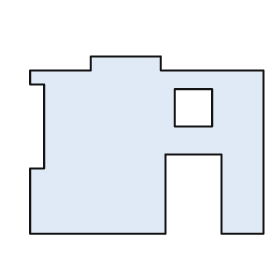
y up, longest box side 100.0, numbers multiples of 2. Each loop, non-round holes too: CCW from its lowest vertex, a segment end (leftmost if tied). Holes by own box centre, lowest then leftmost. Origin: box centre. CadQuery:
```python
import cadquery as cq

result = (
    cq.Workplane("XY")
    .moveTo(-50.0, -38.0)
    .lineTo(8.0, -38.0)
    .lineTo(8.0, -4.0)
    .lineTo(32.0, -4.0)
    .lineTo(32.0, -38.0)
    .lineTo(50.0, -38.0)
    .lineTo(50.0, 32.0)
    .lineTo(6.0, 32.0)
    .lineTo(6.0, 38.0)
    .lineTo(-24.0, 38.0)
    .lineTo(-24.0, 32.0)
    .lineTo(-50.0, 32.0)
    .lineTo(-50.0, 26.0)
    .lineTo(-44.0, 26.0)
    .lineTo(-44.0, -10.0)
    .lineTo(-50.0, -10.0)
    .close()
    .moveTo(12.0, 8.0)
    .lineTo(28.0, 8.0)
    .lineTo(28.0, 24.0)
    .lineTo(12.0, 24.0)
    .close()
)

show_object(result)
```